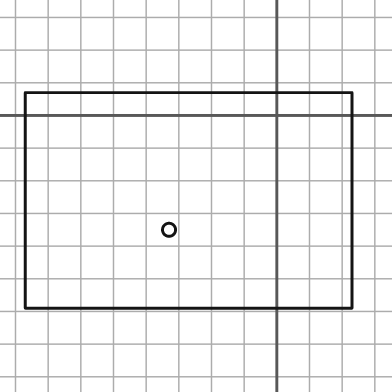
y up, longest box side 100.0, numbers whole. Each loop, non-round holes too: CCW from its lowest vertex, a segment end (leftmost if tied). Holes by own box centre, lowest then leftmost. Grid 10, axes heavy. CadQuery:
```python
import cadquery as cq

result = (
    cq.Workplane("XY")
    .moveTo(-77.0, -59.0)
    .lineTo(23.0, -59.0)
    .lineTo(23.0, 7.0)
    .lineTo(-77.0, 7.0)
    .close()
    .moveTo(-33.0, -35.0)
    .circle(2.0)
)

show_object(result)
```